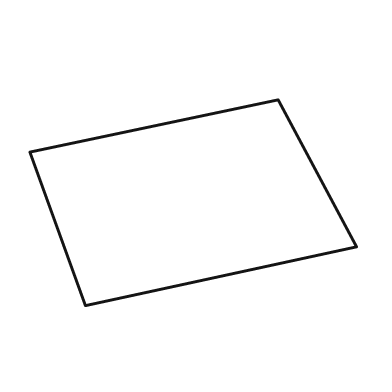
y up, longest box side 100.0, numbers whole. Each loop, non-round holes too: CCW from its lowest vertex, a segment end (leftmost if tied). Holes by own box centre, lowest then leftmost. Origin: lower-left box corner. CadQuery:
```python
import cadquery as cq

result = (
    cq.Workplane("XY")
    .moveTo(17.0, 0.0)
    .lineTo(100.0, 18.0)
    .lineTo(76.0, 63.0)
    .lineTo(0.0, 47.0)
    .close()
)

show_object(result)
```